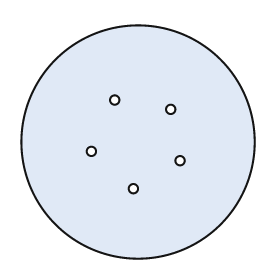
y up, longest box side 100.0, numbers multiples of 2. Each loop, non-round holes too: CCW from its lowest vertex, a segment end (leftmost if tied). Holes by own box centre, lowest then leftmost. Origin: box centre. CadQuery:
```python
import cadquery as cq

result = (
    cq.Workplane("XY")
    .moveTo(0.0, 0.0)
    .circle(50.0)
    .moveTo(-2.0, -20.0)
    .circle(2.0)
    .moveTo(18.0, -8.0)
    .circle(2.0)
    .moveTo(-20.0, -4.0)
    .circle(2.0)
    .moveTo(14.0, 14.0)
    .circle(2.0)
    .moveTo(-10.0, 18.0)
    .circle(2.0)
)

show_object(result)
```